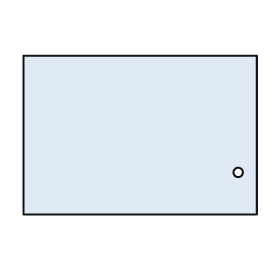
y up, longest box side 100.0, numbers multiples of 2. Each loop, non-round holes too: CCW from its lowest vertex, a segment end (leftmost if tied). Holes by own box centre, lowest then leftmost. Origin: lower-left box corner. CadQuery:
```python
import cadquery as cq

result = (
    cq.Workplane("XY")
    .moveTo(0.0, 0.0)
    .lineTo(100.0, 0.0)
    .lineTo(100.0, 68.0)
    .lineTo(0.0, 68.0)
    .close()
    .moveTo(92.0, 18.0)
    .circle(2.0)
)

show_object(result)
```